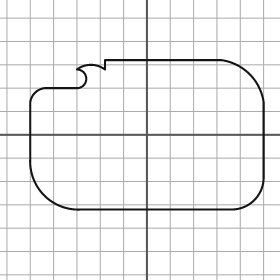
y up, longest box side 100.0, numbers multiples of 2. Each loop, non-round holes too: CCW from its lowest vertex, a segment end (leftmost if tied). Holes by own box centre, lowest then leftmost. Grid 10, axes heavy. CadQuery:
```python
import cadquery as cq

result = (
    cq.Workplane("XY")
    .moveTo(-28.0, -32.0)
    .lineTo(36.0, -32.0)
    .threePointArc((46.0, -28.0), (50.0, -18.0))
    .lineTo(50.0, 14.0)
    .threePointArc((44.0, 26.0), (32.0, 32.0))
    .lineTo(-18.0, 32.0)
    .lineTo(-18.0, 28.0)
    .threePointArc((-24.0, 30.0), (-30.0, 28.0))
    .threePointArc((-26.0, 24.0), (-30.0, 20.0))
    .lineTo(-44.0, 20.0)
    .threePointArc((-48.0, 18.0), (-50.0, 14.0))
    .lineTo(-50.0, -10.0)
    .threePointArc((-44.0, -26.0), (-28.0, -32.0))
    .close()
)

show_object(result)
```